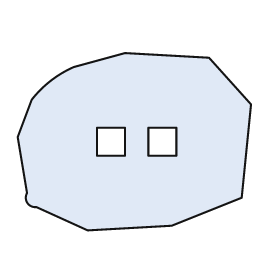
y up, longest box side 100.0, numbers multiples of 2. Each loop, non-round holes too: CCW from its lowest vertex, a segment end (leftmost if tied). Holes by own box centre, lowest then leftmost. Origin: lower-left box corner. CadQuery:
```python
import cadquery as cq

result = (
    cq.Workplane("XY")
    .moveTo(30.0, 0.0)
    .lineTo(66.0, 2.0)
    .lineTo(96.0, 14.0)
    .lineTo(100.0, 54.0)
    .lineTo(82.0, 74.0)
    .lineTo(46.0, 76.0)
    .lineTo(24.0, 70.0)
    .threePointArc((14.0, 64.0), (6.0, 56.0))
    .lineTo(0.0, 40.0)
    .lineTo(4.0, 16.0)
    .threePointArc((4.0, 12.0), (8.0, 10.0))
    .close()
    .moveTo(34.0, 32.0)
    .lineTo(46.0, 32.0)
    .lineTo(46.0, 44.0)
    .lineTo(34.0, 44.0)
    .close()
    .moveTo(56.0, 32.0)
    .lineTo(68.0, 32.0)
    .lineTo(68.0, 44.0)
    .lineTo(56.0, 44.0)
    .close()
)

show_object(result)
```